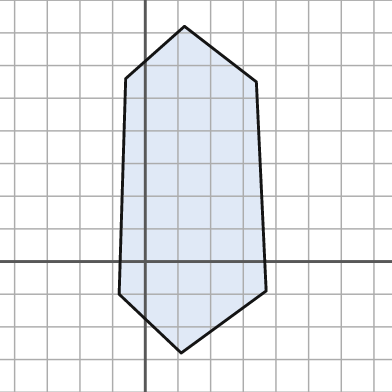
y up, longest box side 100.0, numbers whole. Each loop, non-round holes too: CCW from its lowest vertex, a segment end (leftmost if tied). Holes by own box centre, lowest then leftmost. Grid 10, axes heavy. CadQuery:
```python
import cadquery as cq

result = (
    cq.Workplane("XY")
    .moveTo(11.0, -28.0)
    .lineTo(37.0, -9.0)
    .lineTo(34.0, 55.0)
    .lineTo(12.0, 72.0)
    .lineTo(-6.0, 56.0)
    .lineTo(-8.0, -10.0)
    .close()
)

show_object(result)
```